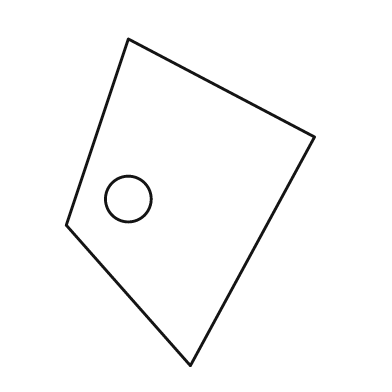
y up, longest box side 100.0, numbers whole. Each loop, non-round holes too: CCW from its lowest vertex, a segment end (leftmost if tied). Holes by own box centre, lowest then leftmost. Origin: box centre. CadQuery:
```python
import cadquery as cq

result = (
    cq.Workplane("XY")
    .moveTo(0.0, -50.0)
    .lineTo(38.0, 20.0)
    .lineTo(-19.0, 50.0)
    .lineTo(-38.0, -7.0)
    .close()
    .moveTo(-19.0, 1.0)
    .circle(7.0)
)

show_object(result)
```